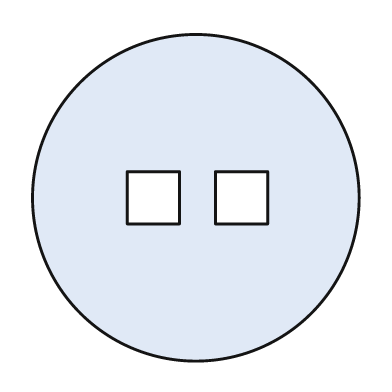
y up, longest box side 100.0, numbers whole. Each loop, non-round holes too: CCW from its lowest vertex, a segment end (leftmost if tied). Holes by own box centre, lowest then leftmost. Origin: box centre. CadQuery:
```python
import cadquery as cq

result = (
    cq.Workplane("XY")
    .moveTo(0.0, 0.0)
    .circle(50.0)
    .moveTo(-21.0, -8.0)
    .lineTo(-5.0, -8.0)
    .lineTo(-5.0, 8.0)
    .lineTo(-21.0, 8.0)
    .close()
    .moveTo(6.0, -8.0)
    .lineTo(22.0, -8.0)
    .lineTo(22.0, 8.0)
    .lineTo(6.0, 8.0)
    .close()
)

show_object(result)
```